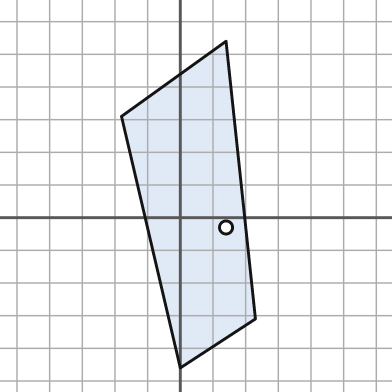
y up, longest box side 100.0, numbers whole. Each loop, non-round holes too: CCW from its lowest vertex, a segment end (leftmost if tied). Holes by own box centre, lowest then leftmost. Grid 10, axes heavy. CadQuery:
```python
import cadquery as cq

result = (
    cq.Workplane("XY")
    .moveTo(0.0, -46.0)
    .lineTo(23.0, -31.0)
    .lineTo(14.0, 54.0)
    .lineTo(-18.0, 31.0)
    .close()
    .moveTo(14.0, -3.0)
    .circle(2.0)
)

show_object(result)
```